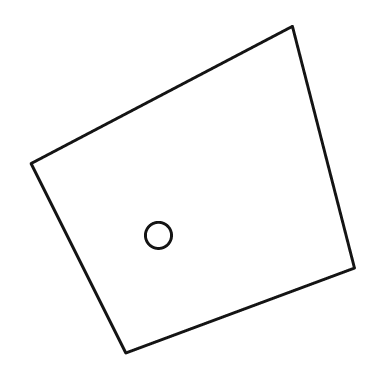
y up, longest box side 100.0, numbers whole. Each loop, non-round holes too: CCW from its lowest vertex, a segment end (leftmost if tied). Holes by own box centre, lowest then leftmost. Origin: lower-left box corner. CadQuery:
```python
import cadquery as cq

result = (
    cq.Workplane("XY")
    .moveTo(29.0, 0.0)
    .lineTo(99.0, 26.0)
    .lineTo(80.0, 100.0)
    .lineTo(0.0, 58.0)
    .close()
    .moveTo(39.0, 36.0)
    .circle(4.0)
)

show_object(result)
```